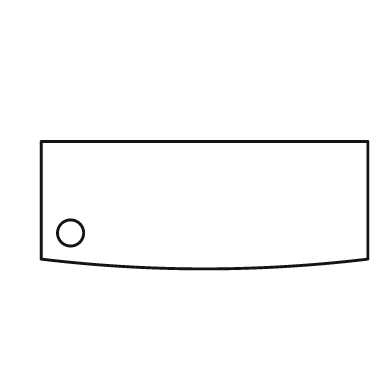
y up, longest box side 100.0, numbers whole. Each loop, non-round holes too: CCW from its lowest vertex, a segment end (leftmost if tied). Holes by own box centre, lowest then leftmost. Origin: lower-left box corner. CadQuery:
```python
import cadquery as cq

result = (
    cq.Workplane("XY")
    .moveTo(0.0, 3.0)
    .threePointArc((50.0, 0.0), (100.0, 3.0))
    .lineTo(100.0, 39.0)
    .lineTo(0.0, 39.0)
    .close()
    .moveTo(9.0, 11.0)
    .circle(4.0)
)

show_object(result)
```